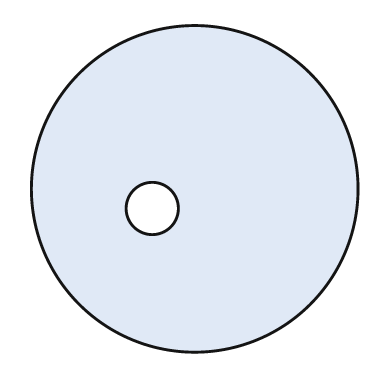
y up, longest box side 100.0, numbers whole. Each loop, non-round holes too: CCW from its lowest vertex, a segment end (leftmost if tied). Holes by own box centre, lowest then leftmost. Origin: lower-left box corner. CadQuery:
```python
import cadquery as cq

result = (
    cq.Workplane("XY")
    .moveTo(50.0, 50.0)
    .circle(50.0)
    .moveTo(37.0, 44.0)
    .circle(8.0)
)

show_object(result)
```